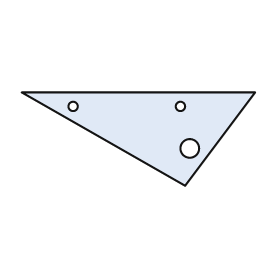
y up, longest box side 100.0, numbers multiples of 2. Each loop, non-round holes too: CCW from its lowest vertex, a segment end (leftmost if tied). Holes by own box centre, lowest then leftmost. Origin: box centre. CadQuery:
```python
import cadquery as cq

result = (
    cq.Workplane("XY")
    .moveTo(20.0, -20.0)
    .lineTo(50.0, 20.0)
    .lineTo(-50.0, 20.0)
    .close()
    .moveTo(22.0, -4.0)
    .circle(4.0)
    .moveTo(-28.0, 14.0)
    .circle(2.0)
    .moveTo(18.0, 14.0)
    .circle(2.0)
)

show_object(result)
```